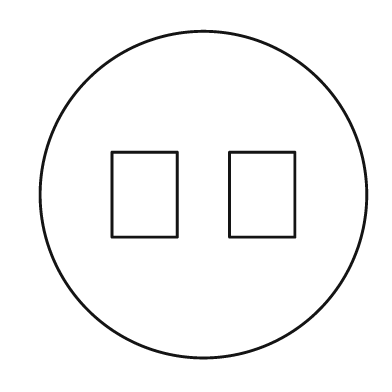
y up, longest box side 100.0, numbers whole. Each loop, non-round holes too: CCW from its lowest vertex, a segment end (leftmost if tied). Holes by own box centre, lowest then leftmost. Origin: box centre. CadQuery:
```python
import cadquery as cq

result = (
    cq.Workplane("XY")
    .moveTo(0.0, 0.0)
    .circle(50.0)
    .moveTo(-28.0, -13.0)
    .lineTo(-8.0, -13.0)
    .lineTo(-8.0, 13.0)
    .lineTo(-28.0, 13.0)
    .close()
    .moveTo(8.0, -13.0)
    .lineTo(28.0, -13.0)
    .lineTo(28.0, 13.0)
    .lineTo(8.0, 13.0)
    .close()
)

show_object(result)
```